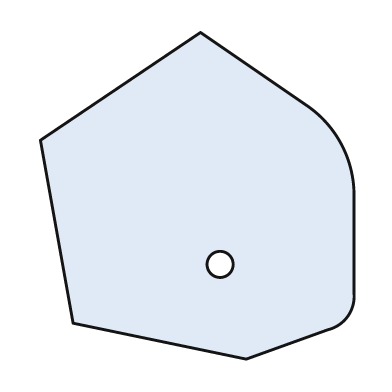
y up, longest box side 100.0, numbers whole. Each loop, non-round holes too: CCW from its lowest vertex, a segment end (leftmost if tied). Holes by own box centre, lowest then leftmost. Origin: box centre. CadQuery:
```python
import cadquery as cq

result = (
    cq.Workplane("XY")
    .moveTo(15.0, -50.0)
    .lineTo(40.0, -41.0)
    .threePointArc((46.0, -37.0), (48.0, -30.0))
    .lineTo(48.0, 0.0)
    .threePointArc((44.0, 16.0), (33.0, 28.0))
    .lineTo(1.0, 50.0)
    .lineTo(-48.0, 17.0)
    .lineTo(-38.0, -39.0)
    .close()
    .moveTo(7.0, -21.0)
    .circle(4.0)
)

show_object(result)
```